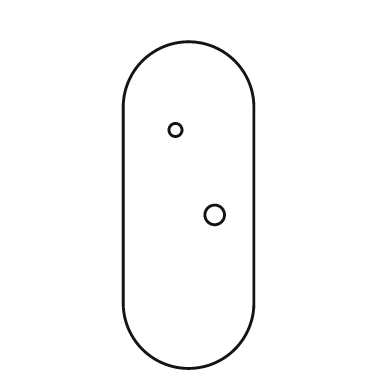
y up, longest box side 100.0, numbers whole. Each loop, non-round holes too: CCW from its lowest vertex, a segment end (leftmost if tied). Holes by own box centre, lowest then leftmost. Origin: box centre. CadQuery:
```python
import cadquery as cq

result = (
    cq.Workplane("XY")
    .moveTo(-20.0, -30.0)
    .threePointArc((0.0, -50.0), (20.0, -30.0))
    .lineTo(20.0, 30.0)
    .threePointArc((0.0, 50.0), (-20.0, 30.0))
    .close()
    .moveTo(8.0, -3.0)
    .circle(3.0)
    .moveTo(-4.0, 23.0)
    .circle(2.0)
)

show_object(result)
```